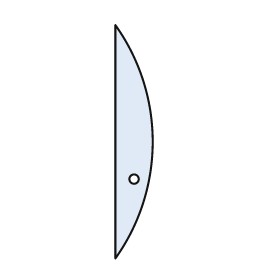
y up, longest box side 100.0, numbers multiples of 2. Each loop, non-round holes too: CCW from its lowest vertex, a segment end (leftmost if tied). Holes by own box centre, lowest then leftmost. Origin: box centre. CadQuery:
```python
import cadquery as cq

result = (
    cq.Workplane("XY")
    .moveTo(-8.0, -50.0)
    .threePointArc((8.0, 0.0), (-8.0, 50.0))
    .close()
    .moveTo(0.0, -16.0)
    .circle(2.0)
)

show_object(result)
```